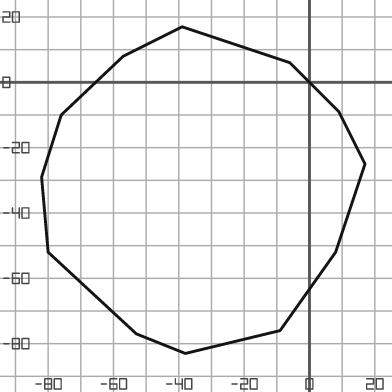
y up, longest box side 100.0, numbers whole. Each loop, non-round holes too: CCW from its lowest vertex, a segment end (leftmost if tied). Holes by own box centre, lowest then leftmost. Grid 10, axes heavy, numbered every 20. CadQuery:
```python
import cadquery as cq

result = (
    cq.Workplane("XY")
    .moveTo(-38.0, -83.0)
    .lineTo(-9.0, -76.0)
    .lineTo(8.0, -52.0)
    .lineTo(17.0, -25.0)
    .lineTo(9.0, -9.0)
    .lineTo(-6.0, 6.0)
    .lineTo(-39.0, 17.0)
    .lineTo(-57.0, 8.0)
    .lineTo(-76.0, -10.0)
    .lineTo(-82.0, -29.0)
    .lineTo(-80.0, -52.0)
    .lineTo(-53.0, -77.0)
    .close()
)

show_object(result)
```